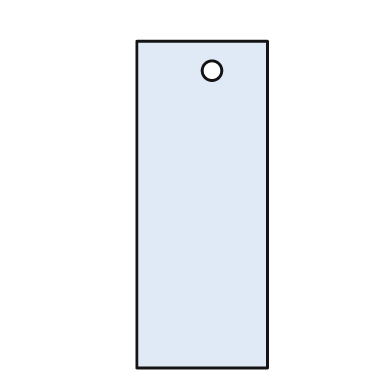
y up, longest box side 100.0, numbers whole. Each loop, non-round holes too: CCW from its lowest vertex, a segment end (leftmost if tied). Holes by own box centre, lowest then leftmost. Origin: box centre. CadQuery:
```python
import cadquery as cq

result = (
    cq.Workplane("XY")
    .moveTo(-20.0, -50.0)
    .lineTo(20.0, -50.0)
    .lineTo(20.0, 50.0)
    .lineTo(-20.0, 50.0)
    .close()
    .moveTo(3.0, 41.0)
    .circle(3.0)
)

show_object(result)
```